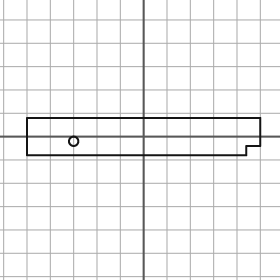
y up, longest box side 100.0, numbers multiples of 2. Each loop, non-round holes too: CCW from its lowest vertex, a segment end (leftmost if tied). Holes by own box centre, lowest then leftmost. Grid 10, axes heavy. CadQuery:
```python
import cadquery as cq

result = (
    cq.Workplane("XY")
    .moveTo(-50.0, -8.0)
    .lineTo(44.0, -8.0)
    .lineTo(44.0, -4.0)
    .lineTo(50.0, -4.0)
    .lineTo(50.0, 8.0)
    .lineTo(-50.0, 8.0)
    .close()
    .moveTo(-30.0, -2.0)
    .circle(2.0)
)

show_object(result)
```